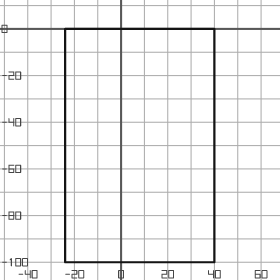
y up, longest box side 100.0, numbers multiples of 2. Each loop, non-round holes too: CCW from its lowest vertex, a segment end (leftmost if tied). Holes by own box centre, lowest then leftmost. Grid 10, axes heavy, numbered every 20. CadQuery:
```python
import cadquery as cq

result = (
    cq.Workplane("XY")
    .moveTo(-24.0, -100.0)
    .lineTo(40.0, -100.0)
    .lineTo(40.0, 0.0)
    .lineTo(-24.0, 0.0)
    .close()
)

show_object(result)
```